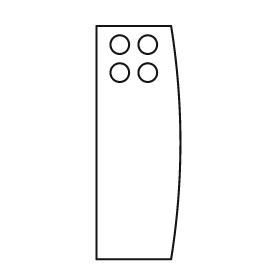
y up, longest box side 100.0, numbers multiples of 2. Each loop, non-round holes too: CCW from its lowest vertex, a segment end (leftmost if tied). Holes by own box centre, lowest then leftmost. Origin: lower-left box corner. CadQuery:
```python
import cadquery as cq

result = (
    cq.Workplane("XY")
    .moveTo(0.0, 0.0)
    .lineTo(32.0, 0.0)
    .threePointArc((36.0, 50.0), (32.0, 100.0))
    .lineTo(0.0, 100.0)
    .close()
    .moveTo(10.0, 80.0)
    .circle(4.0)
    .moveTo(22.0, 80.0)
    .circle(4.0)
    .moveTo(10.0, 92.0)
    .circle(4.0)
    .moveTo(22.0, 92.0)
    .circle(4.0)
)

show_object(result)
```